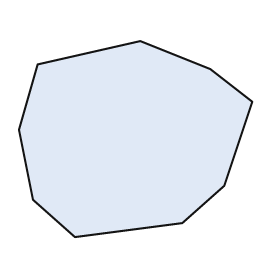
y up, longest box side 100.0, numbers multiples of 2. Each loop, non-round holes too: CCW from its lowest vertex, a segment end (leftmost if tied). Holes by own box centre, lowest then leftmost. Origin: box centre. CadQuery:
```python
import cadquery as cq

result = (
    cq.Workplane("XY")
    .moveTo(-26.0, -42.0)
    .lineTo(20.0, -36.0)
    .lineTo(38.0, -20.0)
    .lineTo(50.0, 16.0)
    .lineTo(32.0, 30.0)
    .lineTo(2.0, 42.0)
    .lineTo(-42.0, 32.0)
    .lineTo(-50.0, 4.0)
    .lineTo(-44.0, -26.0)
    .close()
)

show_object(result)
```